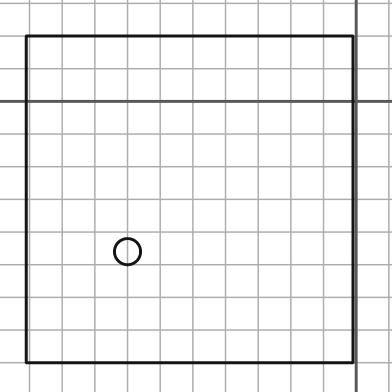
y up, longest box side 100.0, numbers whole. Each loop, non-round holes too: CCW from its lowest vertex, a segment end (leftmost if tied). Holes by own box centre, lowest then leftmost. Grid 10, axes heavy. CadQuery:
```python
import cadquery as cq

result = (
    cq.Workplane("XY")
    .moveTo(-101.0, -80.0)
    .lineTo(-1.0, -80.0)
    .lineTo(-1.0, 20.0)
    .lineTo(-101.0, 20.0)
    .close()
    .moveTo(-70.0, -46.0)
    .circle(4.0)
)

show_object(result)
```